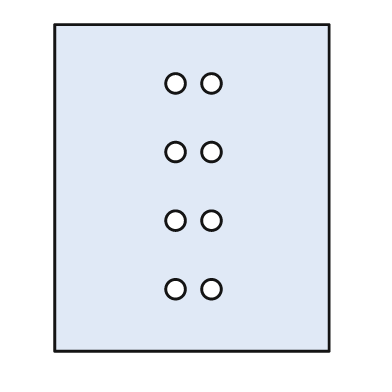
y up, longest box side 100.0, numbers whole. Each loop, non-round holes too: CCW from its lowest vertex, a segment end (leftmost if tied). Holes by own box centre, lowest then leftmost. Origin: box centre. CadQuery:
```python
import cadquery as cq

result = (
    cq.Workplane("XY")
    .moveTo(-42.0, -50.0)
    .lineTo(42.0, -50.0)
    .lineTo(42.0, 50.0)
    .lineTo(-42.0, 50.0)
    .close()
    .moveTo(-5.0, -31.0)
    .circle(3.0)
    .moveTo(6.0, -31.0)
    .circle(3.0)
    .moveTo(-5.0, -10.0)
    .circle(3.0)
    .moveTo(6.0, -10.0)
    .circle(3.0)
    .moveTo(-5.0, 11.0)
    .circle(3.0)
    .moveTo(6.0, 11.0)
    .circle(3.0)
    .moveTo(-5.0, 32.0)
    .circle(3.0)
    .moveTo(6.0, 32.0)
    .circle(3.0)
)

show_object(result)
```